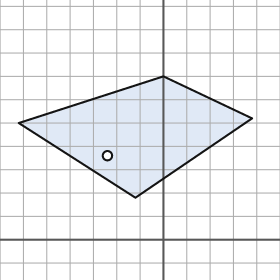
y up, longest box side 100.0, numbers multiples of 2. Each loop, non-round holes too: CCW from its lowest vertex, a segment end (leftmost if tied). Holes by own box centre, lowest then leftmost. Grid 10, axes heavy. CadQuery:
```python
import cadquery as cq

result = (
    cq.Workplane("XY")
    .moveTo(-12.0, 18.0)
    .lineTo(38.0, 52.0)
    .lineTo(0.0, 70.0)
    .lineTo(-62.0, 50.0)
    .close()
    .moveTo(-24.0, 36.0)
    .circle(2.0)
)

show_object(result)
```